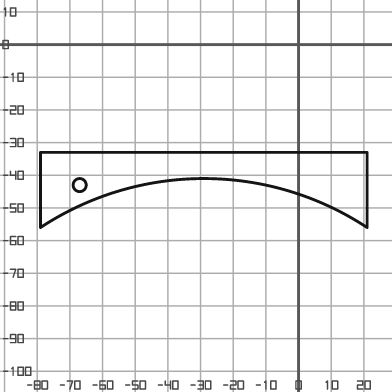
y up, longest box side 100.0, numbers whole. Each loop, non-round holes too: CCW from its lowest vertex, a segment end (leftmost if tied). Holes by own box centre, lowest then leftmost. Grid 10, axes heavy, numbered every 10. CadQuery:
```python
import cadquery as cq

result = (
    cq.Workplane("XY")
    .moveTo(-79.0, -56.0)
    .threePointArc((-29.0, -41.0), (21.0, -56.0))
    .lineTo(21.0, -33.0)
    .lineTo(-79.0, -33.0)
    .close()
    .moveTo(-67.0, -43.0)
    .circle(2.0)
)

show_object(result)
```